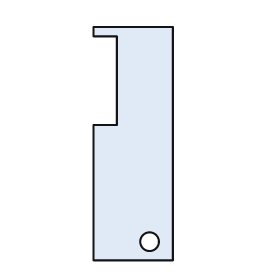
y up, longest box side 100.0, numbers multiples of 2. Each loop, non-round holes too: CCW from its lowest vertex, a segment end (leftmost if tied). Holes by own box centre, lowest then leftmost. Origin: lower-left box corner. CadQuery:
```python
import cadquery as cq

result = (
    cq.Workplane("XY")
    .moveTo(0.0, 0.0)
    .lineTo(34.0, 0.0)
    .lineTo(34.0, 100.0)
    .lineTo(0.0, 100.0)
    .lineTo(0.0, 96.0)
    .lineTo(10.0, 96.0)
    .lineTo(10.0, 58.0)
    .lineTo(0.0, 58.0)
    .close()
    .moveTo(24.0, 8.0)
    .circle(4.0)
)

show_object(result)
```